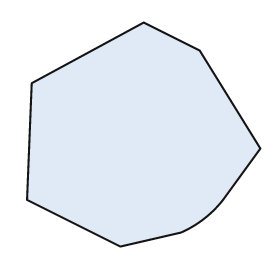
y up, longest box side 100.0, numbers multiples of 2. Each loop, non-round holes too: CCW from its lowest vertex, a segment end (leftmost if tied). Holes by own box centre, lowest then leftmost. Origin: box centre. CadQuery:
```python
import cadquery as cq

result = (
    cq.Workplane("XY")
    .moveTo(-10.0, -48.0)
    .lineTo(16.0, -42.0)
    .threePointArc((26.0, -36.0), (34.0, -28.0))
    .lineTo(50.0, -6.0)
    .lineTo(24.0, 36.0)
    .lineTo(0.0, 48.0)
    .lineTo(-48.0, 22.0)
    .lineTo(-50.0, -28.0)
    .close()
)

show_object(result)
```